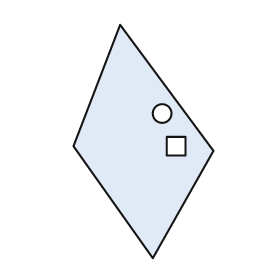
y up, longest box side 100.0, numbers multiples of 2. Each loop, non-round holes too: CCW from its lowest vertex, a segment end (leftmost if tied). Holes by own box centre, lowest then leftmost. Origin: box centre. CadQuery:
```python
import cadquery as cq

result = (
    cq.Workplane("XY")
    .moveTo(4.0, -50.0)
    .lineTo(30.0, -4.0)
    .lineTo(-10.0, 50.0)
    .lineTo(-30.0, -2.0)
    .close()
    .moveTo(10.0, -6.0)
    .lineTo(18.0, -6.0)
    .lineTo(18.0, 2.0)
    .lineTo(10.0, 2.0)
    .close()
    .moveTo(8.0, 12.0)
    .circle(4.0)
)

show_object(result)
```